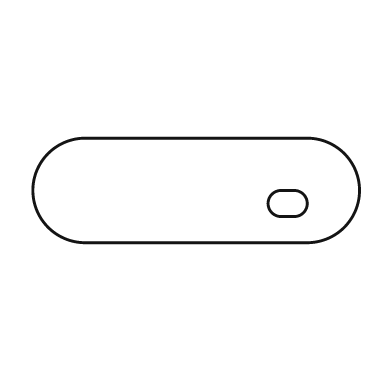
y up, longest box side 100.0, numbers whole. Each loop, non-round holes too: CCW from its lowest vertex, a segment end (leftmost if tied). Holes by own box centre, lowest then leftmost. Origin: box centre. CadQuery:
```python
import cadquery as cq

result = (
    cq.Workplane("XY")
    .moveTo(-34.0, -16.0)
    .lineTo(34.0, -16.0)
    .threePointArc((50.0, 0.0), (34.0, 16.0))
    .lineTo(-34.0, 16.0)
    .threePointArc((-50.0, 0.0), (-34.0, -16.0))
    .close()
    .moveTo(26.0, -8.0)
    .lineTo(30.0, -8.0)
    .threePointArc((34.0, -4.0), (30.0, 0.0))
    .lineTo(26.0, 0.0)
    .threePointArc((22.0, -4.0), (26.0, -8.0))
    .close()
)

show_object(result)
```